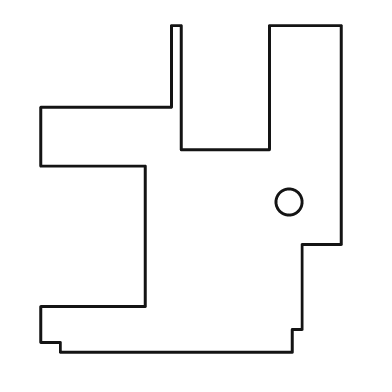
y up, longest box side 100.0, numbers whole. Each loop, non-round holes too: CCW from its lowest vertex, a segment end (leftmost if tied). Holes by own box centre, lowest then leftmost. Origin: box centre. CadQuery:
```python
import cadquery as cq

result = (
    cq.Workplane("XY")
    .moveTo(-40.0, -50.0)
    .lineTo(31.0, -50.0)
    .lineTo(31.0, -43.0)
    .lineTo(34.0, -43.0)
    .lineTo(34.0, -17.0)
    .lineTo(46.0, -17.0)
    .lineTo(46.0, 50.0)
    .lineTo(24.0, 50.0)
    .lineTo(24.0, 12.0)
    .lineTo(-3.0, 12.0)
    .lineTo(-3.0, 50.0)
    .lineTo(-6.0, 50.0)
    .lineTo(-6.0, 25.0)
    .lineTo(-46.0, 25.0)
    .lineTo(-46.0, 7.0)
    .lineTo(-14.0, 7.0)
    .lineTo(-14.0, -36.0)
    .lineTo(-46.0, -36.0)
    .lineTo(-46.0, -47.0)
    .lineTo(-40.0, -47.0)
    .close()
    .moveTo(30.0, -4.0)
    .circle(4.0)
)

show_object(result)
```